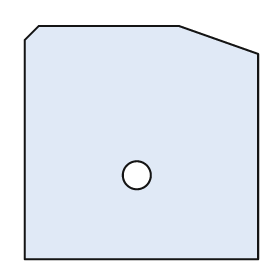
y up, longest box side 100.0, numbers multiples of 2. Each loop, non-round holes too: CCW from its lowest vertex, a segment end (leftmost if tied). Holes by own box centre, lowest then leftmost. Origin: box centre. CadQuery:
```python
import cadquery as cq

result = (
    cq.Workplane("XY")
    .moveTo(-50.0, -50.0)
    .lineTo(50.0, -50.0)
    .lineTo(50.0, 38.0)
    .lineTo(16.0, 50.0)
    .lineTo(-44.0, 50.0)
    .lineTo(-50.0, 44.0)
    .close()
    .moveTo(-2.0, -14.0)
    .circle(6.0)
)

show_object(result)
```